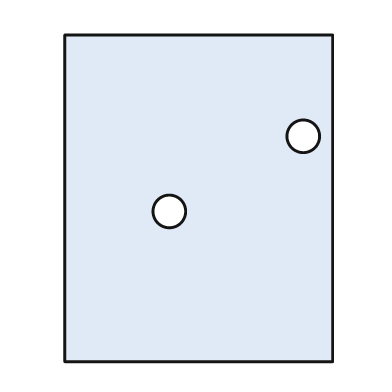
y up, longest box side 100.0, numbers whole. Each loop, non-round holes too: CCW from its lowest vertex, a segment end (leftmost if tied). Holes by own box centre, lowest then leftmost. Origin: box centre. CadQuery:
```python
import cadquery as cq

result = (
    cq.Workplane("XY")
    .moveTo(-41.0, -50.0)
    .lineTo(41.0, -50.0)
    .lineTo(41.0, 50.0)
    .lineTo(-41.0, 50.0)
    .close()
    .moveTo(-9.0, -4.0)
    .circle(5.0)
    .moveTo(32.0, 19.0)
    .circle(5.0)
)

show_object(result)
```